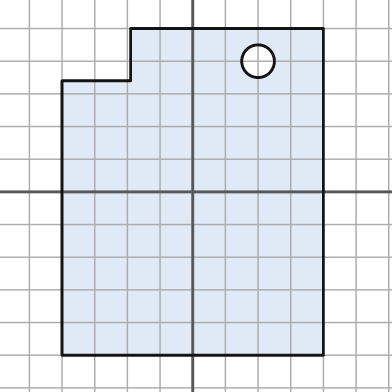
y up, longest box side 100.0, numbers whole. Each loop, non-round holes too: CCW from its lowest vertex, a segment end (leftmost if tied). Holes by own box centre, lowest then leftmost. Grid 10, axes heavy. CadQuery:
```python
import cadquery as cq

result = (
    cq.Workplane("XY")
    .moveTo(-40.0, -50.0)
    .lineTo(40.0, -50.0)
    .lineTo(40.0, 50.0)
    .lineTo(-19.0, 50.0)
    .lineTo(-19.0, 34.0)
    .lineTo(-40.0, 34.0)
    .close()
    .moveTo(20.0, 40.0)
    .circle(5.0)
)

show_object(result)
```